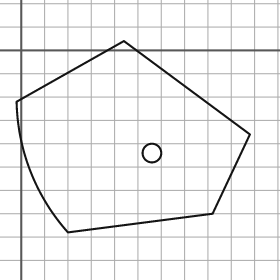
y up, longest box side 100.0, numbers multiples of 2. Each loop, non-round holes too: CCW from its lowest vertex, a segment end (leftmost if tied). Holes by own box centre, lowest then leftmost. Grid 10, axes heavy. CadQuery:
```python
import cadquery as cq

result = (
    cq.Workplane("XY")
    .moveTo(20.0, -78.0)
    .lineTo(82.0, -70.0)
    .lineTo(98.0, -36.0)
    .lineTo(44.0, 4.0)
    .lineTo(-2.0, -22.0)
    .threePointArc((4.0, -52.0), (20.0, -78.0))
    .close()
    .moveTo(56.0, -44.0)
    .circle(4.0)
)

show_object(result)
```